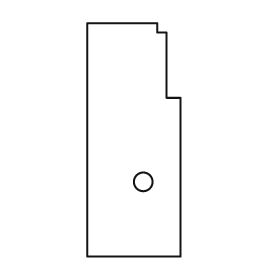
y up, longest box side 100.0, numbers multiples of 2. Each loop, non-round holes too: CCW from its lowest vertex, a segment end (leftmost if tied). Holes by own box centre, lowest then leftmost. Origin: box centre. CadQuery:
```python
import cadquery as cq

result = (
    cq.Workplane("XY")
    .moveTo(-20.0, -50.0)
    .lineTo(20.0, -50.0)
    .lineTo(20.0, 18.0)
    .lineTo(14.0, 18.0)
    .lineTo(14.0, 46.0)
    .lineTo(10.0, 46.0)
    .lineTo(10.0, 50.0)
    .lineTo(-20.0, 50.0)
    .close()
    .moveTo(4.0, -18.0)
    .circle(4.0)
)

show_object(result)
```